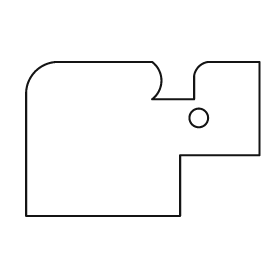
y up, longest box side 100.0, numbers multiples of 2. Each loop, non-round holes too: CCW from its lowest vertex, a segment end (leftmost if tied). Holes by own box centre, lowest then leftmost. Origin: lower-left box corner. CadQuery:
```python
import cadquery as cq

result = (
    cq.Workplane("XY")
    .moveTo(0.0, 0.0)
    .lineTo(66.0, 0.0)
    .lineTo(66.0, 26.0)
    .lineTo(100.0, 26.0)
    .lineTo(100.0, 66.0)
    .lineTo(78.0, 66.0)
    .threePointArc((74.0, 64.0), (72.0, 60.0))
    .lineTo(72.0, 50.0)
    .lineTo(54.0, 50.0)
    .threePointArc((58.0, 58.0), (54.0, 66.0))
    .lineTo(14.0, 66.0)
    .threePointArc((4.0, 62.0), (0.0, 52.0))
    .close()
    .moveTo(74.0, 42.0)
    .circle(4.0)
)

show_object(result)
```